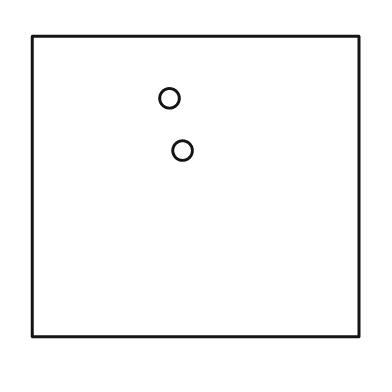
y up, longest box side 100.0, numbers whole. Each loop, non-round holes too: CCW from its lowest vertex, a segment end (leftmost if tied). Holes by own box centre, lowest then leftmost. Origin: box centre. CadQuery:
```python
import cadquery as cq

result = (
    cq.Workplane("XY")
    .moveTo(-50.0, -46.0)
    .lineTo(50.0, -46.0)
    .lineTo(50.0, 46.0)
    .lineTo(-50.0, 46.0)
    .close()
    .moveTo(-4.0, 11.0)
    .circle(3.0)
    .moveTo(-8.0, 27.0)
    .circle(3.0)
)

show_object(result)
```